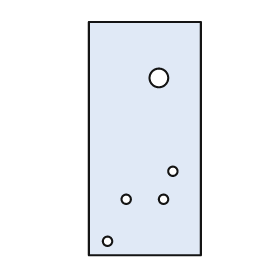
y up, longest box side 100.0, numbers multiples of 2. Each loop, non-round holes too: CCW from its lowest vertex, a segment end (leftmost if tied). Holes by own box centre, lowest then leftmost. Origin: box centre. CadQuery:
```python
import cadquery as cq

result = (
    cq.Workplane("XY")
    .moveTo(-24.0, -50.0)
    .lineTo(24.0, -50.0)
    .lineTo(24.0, 50.0)
    .lineTo(-24.0, 50.0)
    .close()
    .moveTo(-16.0, -44.0)
    .circle(2.0)
    .moveTo(-8.0, -26.0)
    .circle(2.0)
    .moveTo(8.0, -26.0)
    .circle(2.0)
    .moveTo(12.0, -14.0)
    .circle(2.0)
    .moveTo(6.0, 26.0)
    .circle(4.0)
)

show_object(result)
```